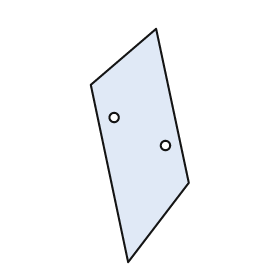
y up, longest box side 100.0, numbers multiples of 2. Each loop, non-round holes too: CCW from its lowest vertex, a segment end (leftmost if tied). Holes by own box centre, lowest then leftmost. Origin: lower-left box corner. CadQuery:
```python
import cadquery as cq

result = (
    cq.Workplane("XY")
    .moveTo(16.0, 0.0)
    .lineTo(42.0, 34.0)
    .lineTo(28.0, 100.0)
    .lineTo(0.0, 76.0)
    .close()
    .moveTo(32.0, 50.0)
    .circle(2.0)
    .moveTo(10.0, 62.0)
    .circle(2.0)
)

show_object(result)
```